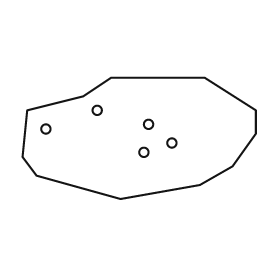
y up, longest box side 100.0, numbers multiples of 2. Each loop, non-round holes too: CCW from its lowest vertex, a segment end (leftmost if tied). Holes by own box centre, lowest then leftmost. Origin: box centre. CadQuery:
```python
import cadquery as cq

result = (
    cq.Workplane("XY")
    .moveTo(-8.0, -26.0)
    .lineTo(26.0, -20.0)
    .lineTo(40.0, -12.0)
    .lineTo(50.0, 2.0)
    .lineTo(50.0, 12.0)
    .lineTo(28.0, 26.0)
    .lineTo(-12.0, 26.0)
    .lineTo(-24.0, 18.0)
    .lineTo(-48.0, 12.0)
    .lineTo(-50.0, -8.0)
    .lineTo(-44.0, -16.0)
    .close()
    .moveTo(2.0, -6.0)
    .circle(2.0)
    .moveTo(14.0, -2.0)
    .circle(2.0)
    .moveTo(-40.0, 4.0)
    .circle(2.0)
    .moveTo(4.0, 6.0)
    .circle(2.0)
    .moveTo(-18.0, 12.0)
    .circle(2.0)
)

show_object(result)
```